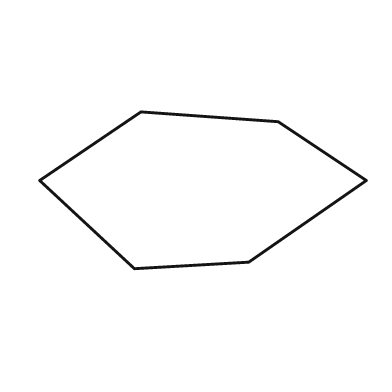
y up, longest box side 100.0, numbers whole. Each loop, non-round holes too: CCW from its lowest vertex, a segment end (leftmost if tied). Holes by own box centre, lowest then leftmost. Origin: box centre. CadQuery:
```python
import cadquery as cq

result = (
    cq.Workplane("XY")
    .moveTo(-21.0, -24.0)
    .lineTo(14.0, -22.0)
    .lineTo(50.0, 3.0)
    .lineTo(23.0, 21.0)
    .lineTo(-19.0, 24.0)
    .lineTo(-50.0, 3.0)
    .close()
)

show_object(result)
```